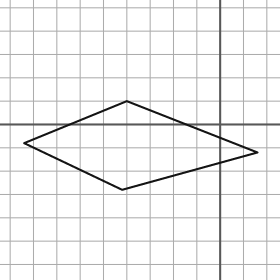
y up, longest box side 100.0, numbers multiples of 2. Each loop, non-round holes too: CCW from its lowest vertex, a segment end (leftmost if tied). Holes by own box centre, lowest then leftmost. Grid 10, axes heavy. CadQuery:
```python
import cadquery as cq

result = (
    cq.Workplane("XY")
    .moveTo(-42.0, -28.0)
    .lineTo(16.0, -12.0)
    .lineTo(-40.0, 10.0)
    .lineTo(-84.0, -8.0)
    .close()
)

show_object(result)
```